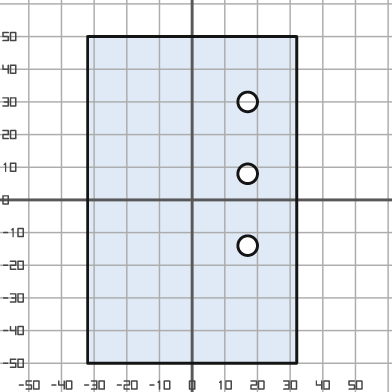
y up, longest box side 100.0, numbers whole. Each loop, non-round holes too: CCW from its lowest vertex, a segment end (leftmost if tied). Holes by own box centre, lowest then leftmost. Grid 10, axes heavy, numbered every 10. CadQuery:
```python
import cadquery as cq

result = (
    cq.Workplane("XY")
    .moveTo(-32.0, -50.0)
    .lineTo(32.0, -50.0)
    .lineTo(32.0, 50.0)
    .lineTo(-32.0, 50.0)
    .close()
    .moveTo(17.0, -14.0)
    .circle(3.0)
    .moveTo(17.0, 8.0)
    .circle(3.0)
    .moveTo(17.0, 30.0)
    .circle(3.0)
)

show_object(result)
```